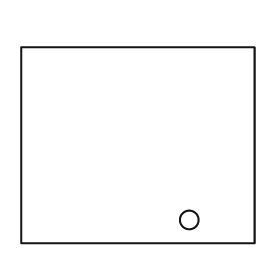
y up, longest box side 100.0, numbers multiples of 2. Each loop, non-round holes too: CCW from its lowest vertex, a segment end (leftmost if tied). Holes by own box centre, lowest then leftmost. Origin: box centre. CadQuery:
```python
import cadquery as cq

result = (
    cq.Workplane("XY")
    .moveTo(-50.0, -42.0)
    .lineTo(50.0, -42.0)
    .lineTo(50.0, 42.0)
    .lineTo(-50.0, 42.0)
    .close()
    .moveTo(22.0, -32.0)
    .circle(4.0)
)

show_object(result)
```